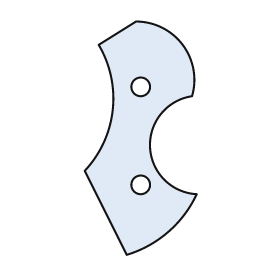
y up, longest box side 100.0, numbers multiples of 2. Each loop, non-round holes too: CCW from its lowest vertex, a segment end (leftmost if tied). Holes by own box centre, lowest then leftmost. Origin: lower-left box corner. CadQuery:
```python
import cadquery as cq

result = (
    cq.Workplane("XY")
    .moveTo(18.0, 0.0)
    .threePointArc((36.0, 10.0), (48.0, 26.0))
    .threePointArc((28.0, 46.0), (46.0, 68.0))
    .threePointArc((42.0, 90.0), (22.0, 100.0))
    .lineTo(6.0, 90.0)
    .threePointArc((12.0, 62.0), (0.0, 36.0))
    .close()
    .moveTo(24.0, 30.0)
    .circle(4.0)
    .moveTo(24.0, 72.0)
    .circle(4.0)
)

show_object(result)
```